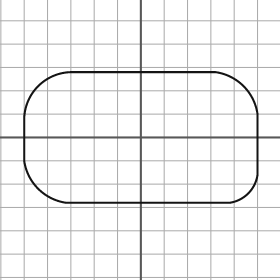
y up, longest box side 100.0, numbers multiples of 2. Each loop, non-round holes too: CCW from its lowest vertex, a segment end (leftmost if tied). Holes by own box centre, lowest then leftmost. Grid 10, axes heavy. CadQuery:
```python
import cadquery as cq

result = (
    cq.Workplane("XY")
    .moveTo(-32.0, -28.0)
    .lineTo(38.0, -28.0)
    .threePointArc((46.0, -24.0), (50.0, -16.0))
    .lineTo(50.0, 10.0)
    .threePointArc((44.0, 22.0), (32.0, 28.0))
    .lineTo(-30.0, 28.0)
    .threePointArc((-44.0, 22.0), (-50.0, 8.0))
    .lineTo(-50.0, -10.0)
    .threePointArc((-44.0, -22.0), (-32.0, -28.0))
    .close()
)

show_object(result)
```